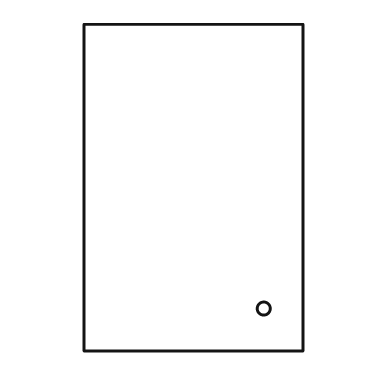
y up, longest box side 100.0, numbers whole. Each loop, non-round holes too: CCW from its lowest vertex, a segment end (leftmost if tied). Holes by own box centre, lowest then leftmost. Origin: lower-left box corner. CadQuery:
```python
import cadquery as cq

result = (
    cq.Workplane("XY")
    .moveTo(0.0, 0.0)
    .lineTo(67.0, 0.0)
    .lineTo(67.0, 100.0)
    .lineTo(0.0, 100.0)
    .close()
    .moveTo(55.0, 13.0)
    .circle(2.0)
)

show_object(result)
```